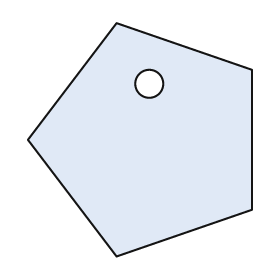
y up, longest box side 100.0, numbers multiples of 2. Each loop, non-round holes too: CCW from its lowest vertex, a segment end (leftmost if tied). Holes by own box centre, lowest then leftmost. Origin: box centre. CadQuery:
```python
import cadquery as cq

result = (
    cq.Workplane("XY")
    .moveTo(-10.0, -50.0)
    .lineTo(48.0, -30.0)
    .lineTo(48.0, 30.0)
    .lineTo(-10.0, 50.0)
    .lineTo(-48.0, 0.0)
    .close()
    .moveTo(4.0, 24.0)
    .circle(6.0)
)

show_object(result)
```